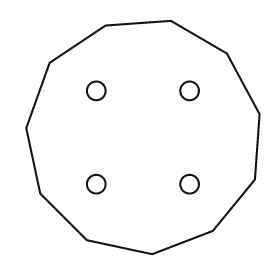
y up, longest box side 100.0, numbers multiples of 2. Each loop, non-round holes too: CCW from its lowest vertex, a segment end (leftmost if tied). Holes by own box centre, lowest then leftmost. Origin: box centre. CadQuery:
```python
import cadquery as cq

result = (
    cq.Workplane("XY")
    .moveTo(4.0, -50.0)
    .lineTo(30.0, -40.0)
    .lineTo(48.0, -18.0)
    .lineTo(50.0, 10.0)
    .lineTo(36.0, 36.0)
    .lineTo(12.0, 50.0)
    .lineTo(-16.0, 48.0)
    .lineTo(-40.0, 32.0)
    .lineTo(-50.0, 4.0)
    .lineTo(-44.0, -24.0)
    .lineTo(-24.0, -44.0)
    .close()
    .moveTo(-20.0, -20.0)
    .circle(4.0)
    .moveTo(20.0, -20.0)
    .circle(4.0)
    .moveTo(-20.0, 20.0)
    .circle(4.0)
    .moveTo(20.0, 20.0)
    .circle(4.0)
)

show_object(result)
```